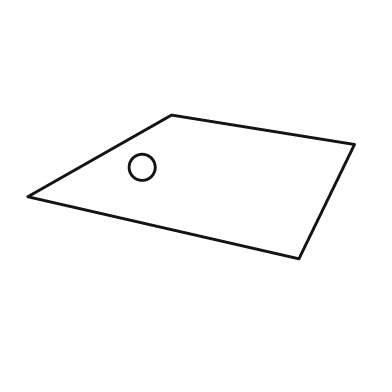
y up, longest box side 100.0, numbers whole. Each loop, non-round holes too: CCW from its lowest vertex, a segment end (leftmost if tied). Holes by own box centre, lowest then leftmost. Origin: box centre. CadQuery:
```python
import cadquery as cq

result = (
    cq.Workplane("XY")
    .moveTo(33.0, -22.0)
    .lineTo(50.0, 13.0)
    .lineTo(-6.0, 22.0)
    .lineTo(-50.0, -3.0)
    .close()
    .moveTo(-15.0, 6.0)
    .circle(4.0)
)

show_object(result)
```